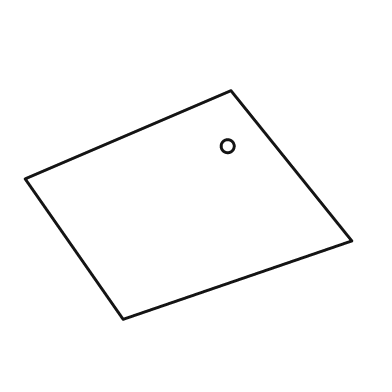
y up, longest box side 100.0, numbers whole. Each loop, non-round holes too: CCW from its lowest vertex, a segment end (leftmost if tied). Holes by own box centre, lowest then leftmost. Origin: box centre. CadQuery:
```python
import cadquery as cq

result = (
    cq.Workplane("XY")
    .moveTo(-20.0, -35.0)
    .lineTo(50.0, -11.0)
    .lineTo(13.0, 35.0)
    .lineTo(-50.0, 8.0)
    .close()
    .moveTo(12.0, 18.0)
    .circle(2.0)
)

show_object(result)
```